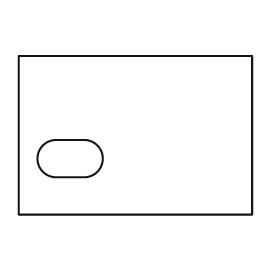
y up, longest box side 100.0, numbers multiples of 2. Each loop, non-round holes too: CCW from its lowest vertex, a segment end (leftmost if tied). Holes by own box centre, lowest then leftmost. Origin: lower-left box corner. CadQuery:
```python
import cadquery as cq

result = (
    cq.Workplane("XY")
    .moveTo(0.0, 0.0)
    .lineTo(100.0, 0.0)
    .lineTo(100.0, 68.0)
    .lineTo(0.0, 68.0)
    .close()
    .moveTo(16.0, 16.0)
    .lineTo(28.0, 16.0)
    .threePointArc((36.0, 24.0), (28.0, 32.0))
    .lineTo(16.0, 32.0)
    .threePointArc((8.0, 24.0), (16.0, 16.0))
    .close()
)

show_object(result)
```